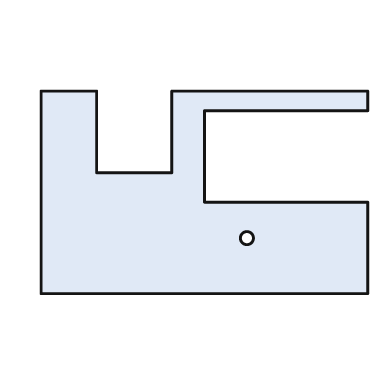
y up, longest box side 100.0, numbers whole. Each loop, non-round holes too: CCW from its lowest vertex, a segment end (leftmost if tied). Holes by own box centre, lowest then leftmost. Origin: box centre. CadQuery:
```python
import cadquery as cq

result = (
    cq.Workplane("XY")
    .moveTo(-50.0, -31.0)
    .lineTo(50.0, -31.0)
    .lineTo(50.0, -3.0)
    .lineTo(0.0, -3.0)
    .lineTo(0.0, 25.0)
    .lineTo(50.0, 25.0)
    .lineTo(50.0, 31.0)
    .lineTo(-10.0, 31.0)
    .lineTo(-10.0, 6.0)
    .lineTo(-33.0, 6.0)
    .lineTo(-33.0, 31.0)
    .lineTo(-50.0, 31.0)
    .close()
    .moveTo(13.0, -14.0)
    .circle(2.0)
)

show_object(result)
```